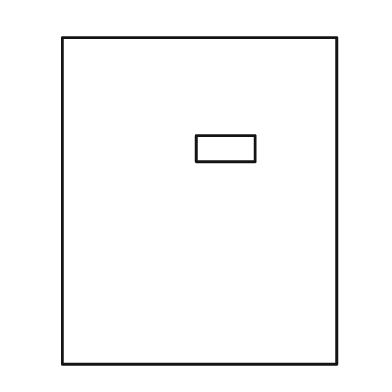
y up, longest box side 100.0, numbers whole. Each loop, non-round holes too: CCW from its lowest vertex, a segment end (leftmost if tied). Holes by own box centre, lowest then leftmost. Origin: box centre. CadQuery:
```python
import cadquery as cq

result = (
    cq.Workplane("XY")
    .moveTo(-42.0, -50.0)
    .lineTo(42.0, -50.0)
    .lineTo(42.0, 50.0)
    .lineTo(-42.0, 50.0)
    .close()
    .moveTo(-1.0, 12.0)
    .lineTo(17.0, 12.0)
    .lineTo(17.0, 20.0)
    .lineTo(-1.0, 20.0)
    .close()
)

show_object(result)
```